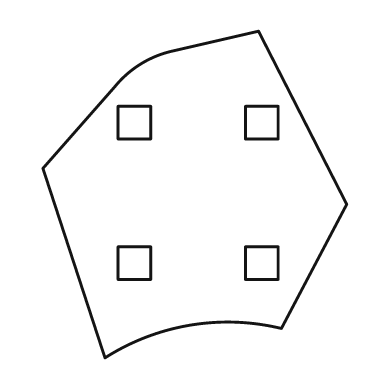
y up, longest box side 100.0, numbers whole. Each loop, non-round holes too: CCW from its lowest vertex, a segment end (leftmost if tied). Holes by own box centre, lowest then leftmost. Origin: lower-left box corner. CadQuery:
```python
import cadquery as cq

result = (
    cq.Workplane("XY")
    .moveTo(19.0, 0.0)
    .threePointArc((45.0, 10.0), (73.0, 9.0))
    .lineTo(93.0, 47.0)
    .lineTo(66.0, 100.0)
    .lineTo(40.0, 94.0)
    .threePointArc((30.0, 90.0), (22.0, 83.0))
    .lineTo(0.0, 58.0)
    .close()
    .moveTo(23.0, 24.0)
    .lineTo(33.0, 24.0)
    .lineTo(33.0, 34.0)
    .lineTo(23.0, 34.0)
    .close()
    .moveTo(62.0, 24.0)
    .lineTo(72.0, 24.0)
    .lineTo(72.0, 34.0)
    .lineTo(62.0, 34.0)
    .close()
    .moveTo(23.0, 67.0)
    .lineTo(33.0, 67.0)
    .lineTo(33.0, 77.0)
    .lineTo(23.0, 77.0)
    .close()
    .moveTo(62.0, 67.0)
    .lineTo(72.0, 67.0)
    .lineTo(72.0, 77.0)
    .lineTo(62.0, 77.0)
    .close()
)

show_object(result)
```